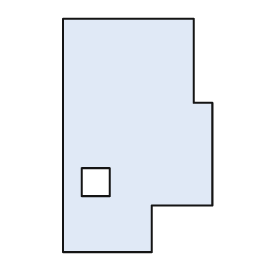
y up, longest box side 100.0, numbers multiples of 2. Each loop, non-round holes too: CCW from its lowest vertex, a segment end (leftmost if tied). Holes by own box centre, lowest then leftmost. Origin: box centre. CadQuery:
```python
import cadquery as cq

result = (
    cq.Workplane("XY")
    .moveTo(-32.0, -50.0)
    .lineTo(6.0, -50.0)
    .lineTo(6.0, -30.0)
    .lineTo(32.0, -30.0)
    .lineTo(32.0, 14.0)
    .lineTo(24.0, 14.0)
    .lineTo(24.0, 50.0)
    .lineTo(-32.0, 50.0)
    .close()
    .moveTo(-24.0, -26.0)
    .lineTo(-12.0, -26.0)
    .lineTo(-12.0, -14.0)
    .lineTo(-24.0, -14.0)
    .close()
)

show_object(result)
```